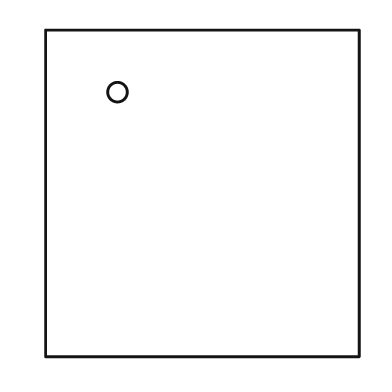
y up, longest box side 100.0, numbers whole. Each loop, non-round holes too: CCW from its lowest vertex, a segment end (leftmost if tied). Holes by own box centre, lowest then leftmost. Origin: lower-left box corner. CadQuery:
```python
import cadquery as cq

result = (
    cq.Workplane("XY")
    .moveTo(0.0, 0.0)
    .lineTo(96.0, 0.0)
    .lineTo(96.0, 100.0)
    .lineTo(0.0, 100.0)
    .close()
    .moveTo(22.0, 81.0)
    .circle(3.0)
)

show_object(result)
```